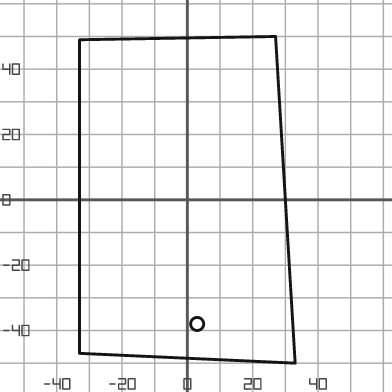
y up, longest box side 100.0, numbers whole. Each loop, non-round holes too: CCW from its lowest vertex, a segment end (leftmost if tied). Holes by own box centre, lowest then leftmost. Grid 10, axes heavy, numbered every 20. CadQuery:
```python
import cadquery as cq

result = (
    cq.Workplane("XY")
    .moveTo(33.0, -50.0)
    .lineTo(27.0, 50.0)
    .lineTo(-33.0, 49.0)
    .lineTo(-33.0, -47.0)
    .close()
    .moveTo(3.0, -38.0)
    .circle(2.0)
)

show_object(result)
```